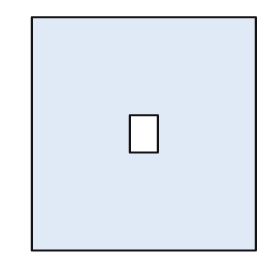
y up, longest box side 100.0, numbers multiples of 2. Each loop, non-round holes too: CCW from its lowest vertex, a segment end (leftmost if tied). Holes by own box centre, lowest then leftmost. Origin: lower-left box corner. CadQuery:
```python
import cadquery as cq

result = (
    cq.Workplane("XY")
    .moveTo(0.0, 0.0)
    .lineTo(96.0, 0.0)
    .lineTo(96.0, 100.0)
    .lineTo(0.0, 100.0)
    .close()
    .moveTo(42.0, 42.0)
    .lineTo(54.0, 42.0)
    .lineTo(54.0, 58.0)
    .lineTo(42.0, 58.0)
    .close()
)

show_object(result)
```